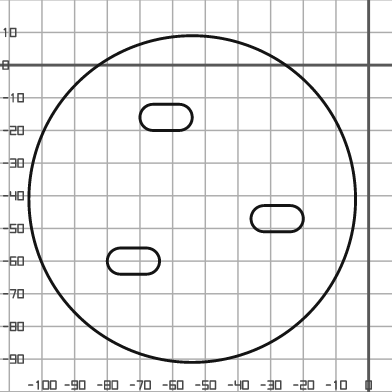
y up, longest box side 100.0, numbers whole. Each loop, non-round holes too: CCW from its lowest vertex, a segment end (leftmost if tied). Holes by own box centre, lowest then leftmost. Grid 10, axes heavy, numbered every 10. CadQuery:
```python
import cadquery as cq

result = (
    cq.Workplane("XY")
    .moveTo(-54.0, -41.0)
    .circle(50.0)
    .moveTo(-76.0, -64.0)
    .lineTo(-68.0, -64.0)
    .threePointArc((-64.0, -60.0), (-68.0, -56.0))
    .lineTo(-76.0, -56.0)
    .threePointArc((-80.0, -60.0), (-76.0, -64.0))
    .close()
    .moveTo(-32.0, -51.0)
    .lineTo(-24.0, -51.0)
    .threePointArc((-20.0, -47.0), (-24.0, -43.0))
    .lineTo(-32.0, -43.0)
    .threePointArc((-36.0, -47.0), (-32.0, -51.0))
    .close()
    .moveTo(-66.0, -20.0)
    .lineTo(-58.0, -20.0)
    .threePointArc((-54.0, -16.0), (-58.0, -12.0))
    .lineTo(-66.0, -12.0)
    .threePointArc((-70.0, -16.0), (-66.0, -20.0))
    .close()
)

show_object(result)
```